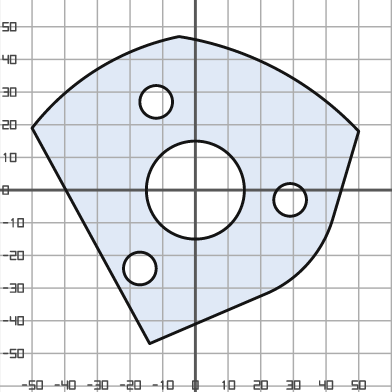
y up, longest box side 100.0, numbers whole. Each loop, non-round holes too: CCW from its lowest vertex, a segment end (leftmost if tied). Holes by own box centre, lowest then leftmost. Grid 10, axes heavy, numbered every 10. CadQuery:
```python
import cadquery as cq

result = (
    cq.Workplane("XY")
    .moveTo(-14.0, -47.0)
    .lineTo(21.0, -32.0)
    .threePointArc((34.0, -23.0), (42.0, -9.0))
    .lineTo(50.0, 18.0)
    .threePointArc((25.0, 37.0), (-5.0, 47.0))
    .threePointArc((-30.0, 37.0), (-50.0, 19.0))
    .close()
    .moveTo(-17.0, -24.0)
    .circle(5.0)
    .moveTo(29.0, -3.0)
    .circle(5.0)
    .moveTo(0.0, 0.0)
    .circle(15.0)
    .moveTo(-12.0, 27.0)
    .circle(5.0)
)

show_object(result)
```